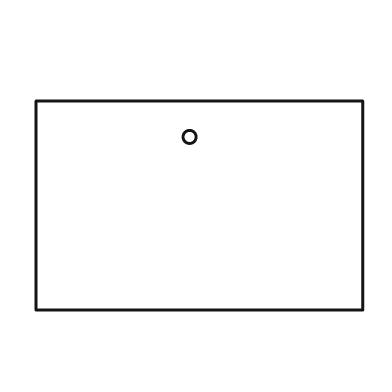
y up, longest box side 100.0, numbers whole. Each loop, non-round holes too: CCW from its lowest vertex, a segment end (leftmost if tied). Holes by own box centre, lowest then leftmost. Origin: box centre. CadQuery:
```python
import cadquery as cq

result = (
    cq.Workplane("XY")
    .moveTo(-50.0, -32.0)
    .lineTo(50.0, -32.0)
    .lineTo(50.0, 32.0)
    .lineTo(-50.0, 32.0)
    .close()
    .moveTo(-3.0, 21.0)
    .circle(2.0)
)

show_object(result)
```